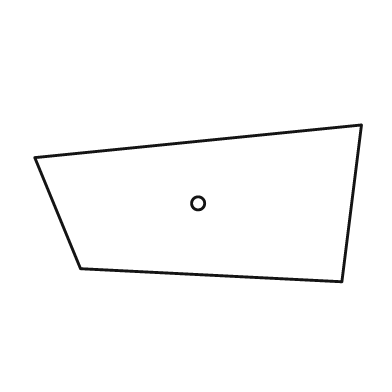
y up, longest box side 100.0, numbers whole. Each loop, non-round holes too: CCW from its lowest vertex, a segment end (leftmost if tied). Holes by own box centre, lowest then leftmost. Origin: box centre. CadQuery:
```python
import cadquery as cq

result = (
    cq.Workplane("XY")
    .moveTo(44.0, -24.0)
    .lineTo(50.0, 24.0)
    .lineTo(-50.0, 14.0)
    .lineTo(-36.0, -20.0)
    .close()
    .moveTo(0.0, 0.0)
    .circle(2.0)
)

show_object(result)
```